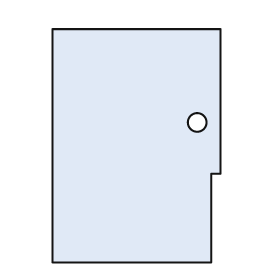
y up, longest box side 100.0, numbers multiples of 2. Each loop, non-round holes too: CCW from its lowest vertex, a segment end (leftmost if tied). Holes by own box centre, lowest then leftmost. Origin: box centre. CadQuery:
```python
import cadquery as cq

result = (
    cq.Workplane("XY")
    .moveTo(-36.0, -50.0)
    .lineTo(32.0, -50.0)
    .lineTo(32.0, -12.0)
    .lineTo(36.0, -12.0)
    .lineTo(36.0, 50.0)
    .lineTo(-36.0, 50.0)
    .close()
    .moveTo(26.0, 10.0)
    .circle(4.0)
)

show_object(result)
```